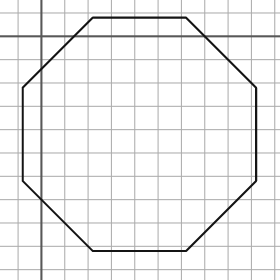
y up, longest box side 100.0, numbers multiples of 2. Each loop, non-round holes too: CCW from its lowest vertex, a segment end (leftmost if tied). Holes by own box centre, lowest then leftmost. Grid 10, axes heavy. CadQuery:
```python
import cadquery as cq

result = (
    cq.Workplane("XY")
    .moveTo(22.0, -92.0)
    .lineTo(62.0, -92.0)
    .lineTo(92.0, -62.0)
    .lineTo(92.0, -22.0)
    .lineTo(62.0, 8.0)
    .lineTo(22.0, 8.0)
    .lineTo(-8.0, -22.0)
    .lineTo(-8.0, -62.0)
    .close()
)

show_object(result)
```